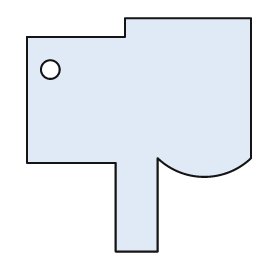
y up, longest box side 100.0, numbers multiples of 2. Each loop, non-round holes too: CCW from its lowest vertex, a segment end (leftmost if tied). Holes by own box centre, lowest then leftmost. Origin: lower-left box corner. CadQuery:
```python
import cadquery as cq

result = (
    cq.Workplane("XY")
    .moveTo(38.0, 0.0)
    .lineTo(56.0, 0.0)
    .lineTo(56.0, 40.0)
    .threePointArc((76.0, 32.0), (96.0, 40.0))
    .lineTo(96.0, 100.0)
    .lineTo(42.0, 100.0)
    .lineTo(42.0, 92.0)
    .lineTo(0.0, 92.0)
    .lineTo(0.0, 38.0)
    .lineTo(38.0, 38.0)
    .close()
    .moveTo(10.0, 78.0)
    .circle(4.0)
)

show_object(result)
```